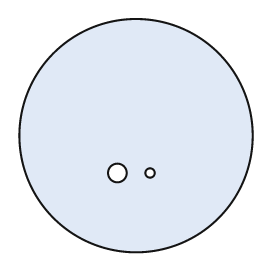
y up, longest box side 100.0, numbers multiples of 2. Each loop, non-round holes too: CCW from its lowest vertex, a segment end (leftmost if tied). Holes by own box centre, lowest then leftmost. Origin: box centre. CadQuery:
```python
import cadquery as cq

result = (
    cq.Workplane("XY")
    .moveTo(0.0, 0.0)
    .circle(50.0)
    .moveTo(-8.0, -16.0)
    .circle(4.0)
    .moveTo(6.0, -16.0)
    .circle(2.0)
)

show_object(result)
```